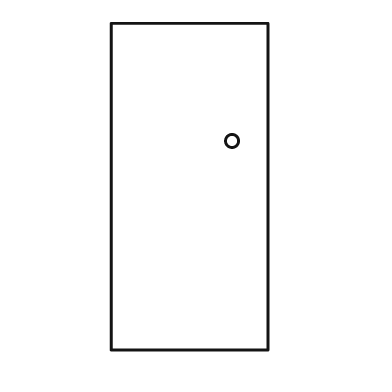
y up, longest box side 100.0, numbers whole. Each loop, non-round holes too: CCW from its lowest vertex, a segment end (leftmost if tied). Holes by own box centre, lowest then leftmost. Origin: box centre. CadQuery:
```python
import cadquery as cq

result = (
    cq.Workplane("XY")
    .moveTo(-24.0, -50.0)
    .lineTo(24.0, -50.0)
    .lineTo(24.0, 50.0)
    .lineTo(-24.0, 50.0)
    .close()
    .moveTo(13.0, 14.0)
    .circle(2.0)
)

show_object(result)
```